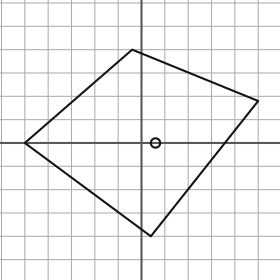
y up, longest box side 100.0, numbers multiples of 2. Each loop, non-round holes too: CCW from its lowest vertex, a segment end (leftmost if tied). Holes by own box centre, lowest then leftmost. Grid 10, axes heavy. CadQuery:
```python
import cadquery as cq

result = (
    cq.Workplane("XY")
    .moveTo(4.0, -40.0)
    .lineTo(50.0, 18.0)
    .lineTo(-4.0, 40.0)
    .lineTo(-50.0, 0.0)
    .close()
    .moveTo(6.0, 0.0)
    .circle(2.0)
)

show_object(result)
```